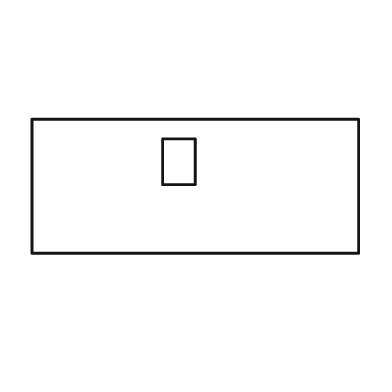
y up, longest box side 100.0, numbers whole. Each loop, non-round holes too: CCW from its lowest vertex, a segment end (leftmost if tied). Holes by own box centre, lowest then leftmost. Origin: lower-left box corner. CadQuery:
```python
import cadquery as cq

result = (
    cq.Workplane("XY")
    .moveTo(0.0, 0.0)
    .lineTo(100.0, 0.0)
    .lineTo(100.0, 41.0)
    .lineTo(0.0, 41.0)
    .close()
    .moveTo(40.0, 21.0)
    .lineTo(50.0, 21.0)
    .lineTo(50.0, 35.0)
    .lineTo(40.0, 35.0)
    .close()
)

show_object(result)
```